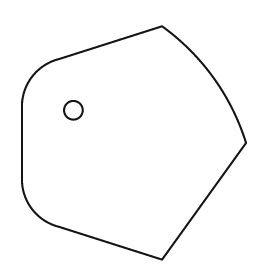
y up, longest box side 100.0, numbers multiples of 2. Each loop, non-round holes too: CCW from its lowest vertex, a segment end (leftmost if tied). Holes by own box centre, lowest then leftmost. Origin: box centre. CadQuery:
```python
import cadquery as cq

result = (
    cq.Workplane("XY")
    .moveTo(12.0, -50.0)
    .lineTo(48.0, 0.0)
    .threePointArc((34.0, 28.0), (12.0, 50.0))
    .lineTo(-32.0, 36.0)
    .threePointArc((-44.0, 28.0), (-48.0, 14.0))
    .lineTo(-48.0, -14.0)
    .threePointArc((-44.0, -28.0), (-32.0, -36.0))
    .close()
    .moveTo(-26.0, 14.0)
    .circle(4.0)
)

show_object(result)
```